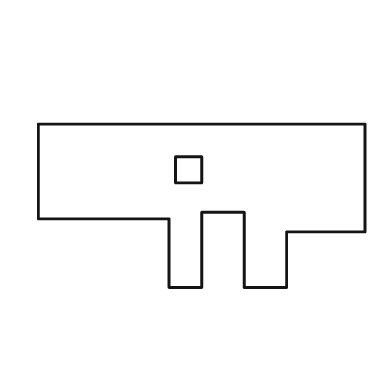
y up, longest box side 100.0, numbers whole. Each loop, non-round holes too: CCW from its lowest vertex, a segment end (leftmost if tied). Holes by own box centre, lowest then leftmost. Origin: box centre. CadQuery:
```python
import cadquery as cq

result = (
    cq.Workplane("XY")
    .moveTo(-10.0, -25.0)
    .lineTo(0.0, -25.0)
    .lineTo(0.0, -2.0)
    .lineTo(13.0, -2.0)
    .lineTo(13.0, -25.0)
    .lineTo(26.0, -25.0)
    .lineTo(26.0, -8.0)
    .lineTo(50.0, -8.0)
    .lineTo(50.0, 25.0)
    .lineTo(-50.0, 25.0)
    .lineTo(-50.0, -4.0)
    .lineTo(-10.0, -4.0)
    .close()
    .moveTo(-8.0, 7.0)
    .lineTo(0.0, 7.0)
    .lineTo(0.0, 15.0)
    .lineTo(-8.0, 15.0)
    .close()
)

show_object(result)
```